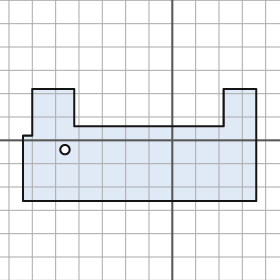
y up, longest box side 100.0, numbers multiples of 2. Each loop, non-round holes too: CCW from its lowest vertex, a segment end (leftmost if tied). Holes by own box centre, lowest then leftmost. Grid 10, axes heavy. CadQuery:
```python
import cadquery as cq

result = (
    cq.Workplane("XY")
    .moveTo(-64.0, -26.0)
    .lineTo(36.0, -26.0)
    .lineTo(36.0, 22.0)
    .lineTo(22.0, 22.0)
    .lineTo(22.0, 6.0)
    .lineTo(-42.0, 6.0)
    .lineTo(-42.0, 22.0)
    .lineTo(-60.0, 22.0)
    .lineTo(-60.0, 2.0)
    .lineTo(-64.0, 2.0)
    .close()
    .moveTo(-46.0, -4.0)
    .circle(2.0)
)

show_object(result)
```